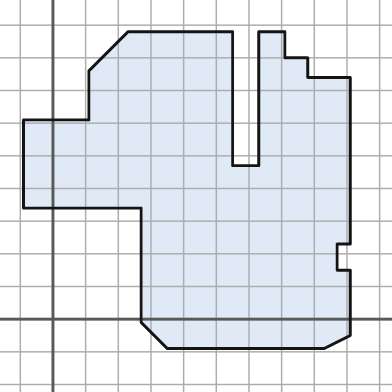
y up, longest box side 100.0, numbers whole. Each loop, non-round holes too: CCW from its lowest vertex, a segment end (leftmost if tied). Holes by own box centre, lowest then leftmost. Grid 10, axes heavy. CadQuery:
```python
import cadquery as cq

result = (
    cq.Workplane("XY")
    .moveTo(35.0, -9.0)
    .lineTo(83.0, -9.0)
    .lineTo(91.0, -5.0)
    .lineTo(91.0, 15.0)
    .lineTo(87.0, 15.0)
    .lineTo(87.0, 23.0)
    .lineTo(91.0, 23.0)
    .lineTo(91.0, 74.0)
    .lineTo(78.0, 74.0)
    .lineTo(78.0, 80.0)
    .lineTo(71.0, 80.0)
    .lineTo(71.0, 88.0)
    .lineTo(63.0, 88.0)
    .lineTo(63.0, 47.0)
    .lineTo(55.0, 47.0)
    .lineTo(55.0, 88.0)
    .lineTo(23.0, 88.0)
    .lineTo(11.0, 76.0)
    .lineTo(11.0, 61.0)
    .lineTo(-9.0, 61.0)
    .lineTo(-9.0, 34.0)
    .lineTo(27.0, 34.0)
    .lineTo(27.0, -1.0)
    .close()
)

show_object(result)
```